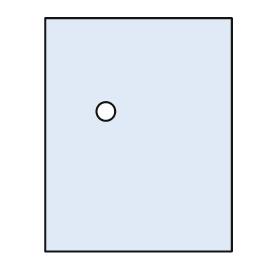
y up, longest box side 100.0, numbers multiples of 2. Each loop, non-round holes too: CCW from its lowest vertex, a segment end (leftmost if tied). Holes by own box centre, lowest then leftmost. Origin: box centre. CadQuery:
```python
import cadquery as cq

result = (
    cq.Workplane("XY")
    .moveTo(-40.0, -50.0)
    .lineTo(40.0, -50.0)
    .lineTo(40.0, 50.0)
    .lineTo(-40.0, 50.0)
    .close()
    .moveTo(-14.0, 10.0)
    .circle(4.0)
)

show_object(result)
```